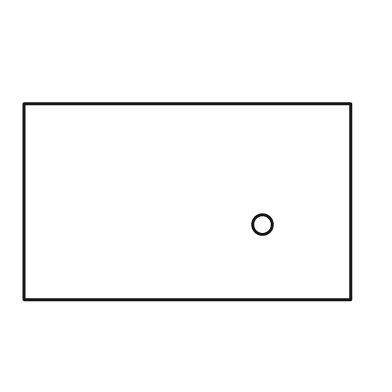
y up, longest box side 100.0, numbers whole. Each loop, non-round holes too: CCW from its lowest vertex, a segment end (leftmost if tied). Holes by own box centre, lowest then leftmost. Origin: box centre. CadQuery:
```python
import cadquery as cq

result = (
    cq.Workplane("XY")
    .moveTo(-50.0, -30.0)
    .lineTo(50.0, -30.0)
    .lineTo(50.0, 30.0)
    .lineTo(-50.0, 30.0)
    .close()
    .moveTo(23.0, -7.0)
    .circle(3.0)
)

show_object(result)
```